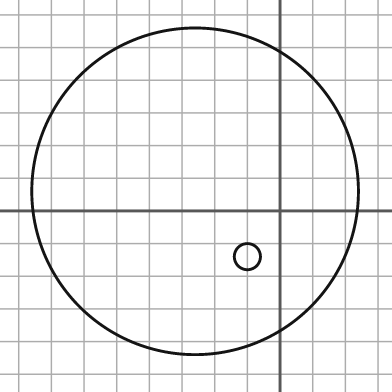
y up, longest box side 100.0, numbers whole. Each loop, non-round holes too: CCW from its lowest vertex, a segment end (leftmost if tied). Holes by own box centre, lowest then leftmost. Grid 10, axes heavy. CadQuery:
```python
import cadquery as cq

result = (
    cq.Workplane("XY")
    .moveTo(-26.0, 6.0)
    .circle(50.0)
    .moveTo(-10.0, -14.0)
    .circle(4.0)
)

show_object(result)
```